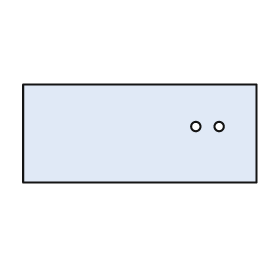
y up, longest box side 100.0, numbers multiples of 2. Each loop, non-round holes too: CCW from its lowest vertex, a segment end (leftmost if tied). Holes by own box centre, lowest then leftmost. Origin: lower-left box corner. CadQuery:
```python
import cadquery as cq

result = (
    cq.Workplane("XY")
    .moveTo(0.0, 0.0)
    .lineTo(100.0, 0.0)
    .lineTo(100.0, 42.0)
    .lineTo(0.0, 42.0)
    .close()
    .moveTo(74.0, 24.0)
    .circle(2.0)
    .moveTo(84.0, 24.0)
    .circle(2.0)
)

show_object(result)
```